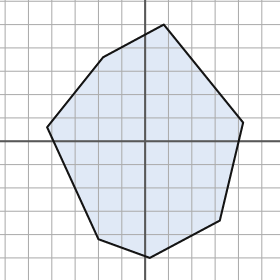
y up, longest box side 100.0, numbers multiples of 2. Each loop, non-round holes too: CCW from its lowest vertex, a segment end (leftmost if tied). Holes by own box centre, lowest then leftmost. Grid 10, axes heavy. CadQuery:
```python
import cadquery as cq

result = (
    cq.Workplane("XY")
    .moveTo(2.0, -50.0)
    .lineTo(32.0, -34.0)
    .lineTo(42.0, 8.0)
    .lineTo(8.0, 50.0)
    .lineTo(-18.0, 36.0)
    .lineTo(-42.0, 6.0)
    .lineTo(-20.0, -42.0)
    .close()
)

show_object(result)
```